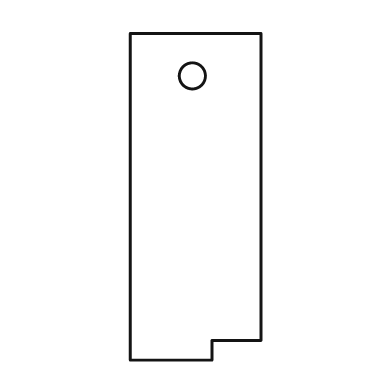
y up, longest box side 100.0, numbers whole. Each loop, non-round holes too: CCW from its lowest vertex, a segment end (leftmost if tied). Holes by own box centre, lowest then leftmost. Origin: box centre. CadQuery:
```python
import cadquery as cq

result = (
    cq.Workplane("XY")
    .moveTo(-20.0, -50.0)
    .lineTo(5.0, -50.0)
    .lineTo(5.0, -44.0)
    .lineTo(20.0, -44.0)
    .lineTo(20.0, 50.0)
    .lineTo(-20.0, 50.0)
    .close()
    .moveTo(-1.0, 37.0)
    .circle(4.0)
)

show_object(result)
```